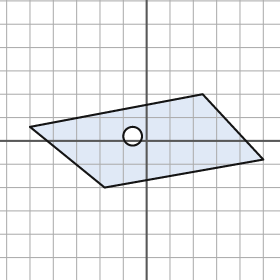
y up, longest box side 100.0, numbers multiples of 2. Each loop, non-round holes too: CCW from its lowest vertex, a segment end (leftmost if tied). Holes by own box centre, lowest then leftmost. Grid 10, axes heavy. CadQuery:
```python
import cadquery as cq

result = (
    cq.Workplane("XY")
    .moveTo(-18.0, -20.0)
    .lineTo(50.0, -8.0)
    .lineTo(24.0, 20.0)
    .lineTo(-50.0, 6.0)
    .close()
    .moveTo(-6.0, 2.0)
    .circle(4.0)
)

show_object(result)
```